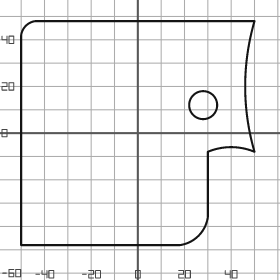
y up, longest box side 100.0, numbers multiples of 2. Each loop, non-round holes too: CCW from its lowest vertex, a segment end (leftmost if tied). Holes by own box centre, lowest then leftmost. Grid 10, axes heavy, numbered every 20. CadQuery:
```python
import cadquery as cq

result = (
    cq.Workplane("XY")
    .moveTo(-50.0, -48.0)
    .lineTo(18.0, -48.0)
    .threePointArc((26.0, -44.0), (30.0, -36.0))
    .lineTo(30.0, -8.0)
    .threePointArc((40.0, -6.0), (50.0, -8.0))
    .threePointArc((46.0, 20.0), (50.0, 48.0))
    .lineTo(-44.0, 48.0)
    .threePointArc((-48.0, 46.0), (-50.0, 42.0))
    .close()
    .moveTo(28.0, 12.0)
    .circle(6.0)
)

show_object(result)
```